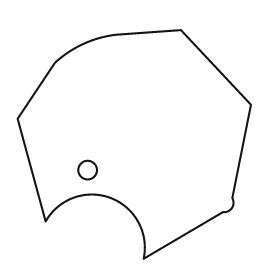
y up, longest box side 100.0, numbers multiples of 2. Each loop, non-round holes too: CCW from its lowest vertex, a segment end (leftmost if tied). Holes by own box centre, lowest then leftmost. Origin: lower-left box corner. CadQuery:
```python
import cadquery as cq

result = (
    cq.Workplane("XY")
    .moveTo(54.0, 0.0)
    .lineTo(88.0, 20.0)
    .threePointArc((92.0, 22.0), (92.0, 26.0))
    .lineTo(100.0, 66.0)
    .lineTo(70.0, 98.0)
    .lineTo(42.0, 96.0)
    .threePointArc((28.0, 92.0), (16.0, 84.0))
    .lineTo(0.0, 60.0)
    .lineTo(12.0, 16.0)
    .threePointArc((40.0, 26.0), (54.0, 0.0))
    .close()
    .moveTo(30.0, 38.0)
    .circle(4.0)
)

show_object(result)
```